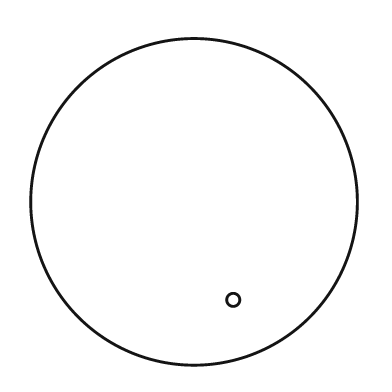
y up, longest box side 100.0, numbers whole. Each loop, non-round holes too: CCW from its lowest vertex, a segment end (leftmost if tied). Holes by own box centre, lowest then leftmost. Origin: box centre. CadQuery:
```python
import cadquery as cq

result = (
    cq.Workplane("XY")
    .moveTo(0.0, 0.0)
    .circle(50.0)
    .moveTo(12.0, -30.0)
    .circle(2.0)
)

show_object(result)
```